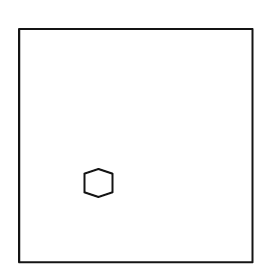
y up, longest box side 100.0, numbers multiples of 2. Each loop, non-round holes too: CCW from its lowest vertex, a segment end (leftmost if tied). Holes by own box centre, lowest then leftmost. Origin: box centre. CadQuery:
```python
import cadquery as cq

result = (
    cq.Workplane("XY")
    .moveTo(-50.0, -50.0)
    .lineTo(50.0, -50.0)
    .lineTo(50.0, 50.0)
    .lineTo(-50.0, 50.0)
    .close()
    .moveTo(-16.0, -22.0)
    .lineTo(-10.0, -20.0)
    .lineTo(-10.0, -12.0)
    .lineTo(-16.0, -10.0)
    .lineTo(-22.0, -12.0)
    .lineTo(-22.0, -20.0)
    .close()
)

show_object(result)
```